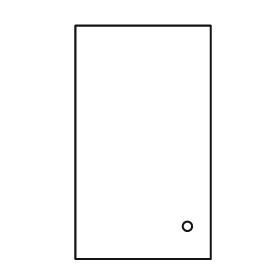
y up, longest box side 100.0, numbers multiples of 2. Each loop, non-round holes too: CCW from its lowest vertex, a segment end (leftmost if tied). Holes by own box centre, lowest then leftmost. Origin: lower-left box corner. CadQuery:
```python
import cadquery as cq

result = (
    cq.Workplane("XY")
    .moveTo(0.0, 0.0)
    .lineTo(58.0, 0.0)
    .lineTo(58.0, 100.0)
    .lineTo(0.0, 100.0)
    .close()
    .moveTo(48.0, 14.0)
    .circle(2.0)
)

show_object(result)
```